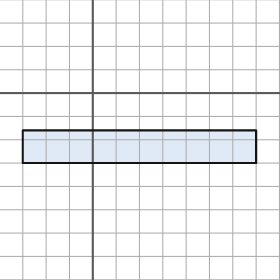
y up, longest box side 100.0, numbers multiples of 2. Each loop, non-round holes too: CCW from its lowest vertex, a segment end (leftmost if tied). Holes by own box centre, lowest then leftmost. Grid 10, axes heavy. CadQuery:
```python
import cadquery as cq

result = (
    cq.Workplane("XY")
    .moveTo(-30.0, -30.0)
    .lineTo(70.0, -30.0)
    .lineTo(70.0, -16.0)
    .lineTo(-30.0, -16.0)
    .close()
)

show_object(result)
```